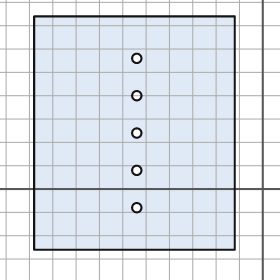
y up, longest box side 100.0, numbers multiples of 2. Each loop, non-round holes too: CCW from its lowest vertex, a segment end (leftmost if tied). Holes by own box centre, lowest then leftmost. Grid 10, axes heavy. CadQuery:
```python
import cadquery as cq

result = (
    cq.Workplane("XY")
    .moveTo(-98.0, -26.0)
    .lineTo(-12.0, -26.0)
    .lineTo(-12.0, 74.0)
    .lineTo(-98.0, 74.0)
    .close()
    .moveTo(-54.0, -8.0)
    .circle(2.0)
    .moveTo(-54.0, 8.0)
    .circle(2.0)
    .moveTo(-54.0, 24.0)
    .circle(2.0)
    .moveTo(-54.0, 40.0)
    .circle(2.0)
    .moveTo(-54.0, 56.0)
    .circle(2.0)
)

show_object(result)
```